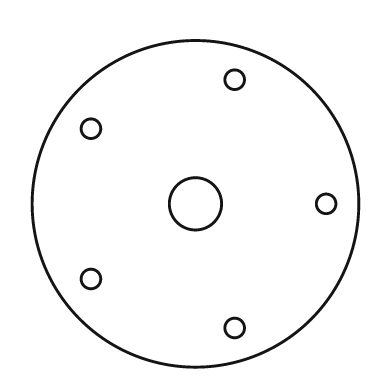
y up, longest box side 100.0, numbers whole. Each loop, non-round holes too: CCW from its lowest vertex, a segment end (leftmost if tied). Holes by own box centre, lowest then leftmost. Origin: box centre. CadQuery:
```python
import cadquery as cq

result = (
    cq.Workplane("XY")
    .moveTo(0.0, 0.0)
    .circle(50.0)
    .moveTo(12.0, -38.0)
    .circle(3.0)
    .moveTo(-32.0, -23.0)
    .circle(3.0)
    .moveTo(0.0, 0.0)
    .circle(8.0)
    .moveTo(40.0, 0.0)
    .circle(3.0)
    .moveTo(-32.0, 23.0)
    .circle(3.0)
    .moveTo(12.0, 38.0)
    .circle(3.0)
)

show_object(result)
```